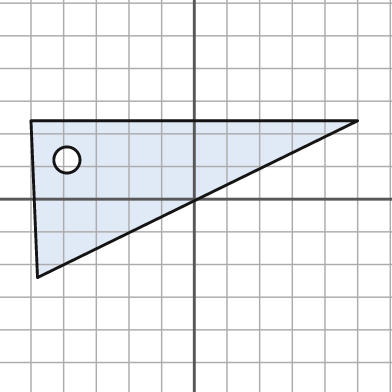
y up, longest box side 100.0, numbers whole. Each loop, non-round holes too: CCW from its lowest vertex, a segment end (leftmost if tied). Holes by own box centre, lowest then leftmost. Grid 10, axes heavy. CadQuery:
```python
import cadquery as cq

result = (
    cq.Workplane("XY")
    .moveTo(-48.0, -24.0)
    .lineTo(50.0, 24.0)
    .lineTo(-50.0, 24.0)
    .close()
    .moveTo(-39.0, 12.0)
    .circle(4.0)
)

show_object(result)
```